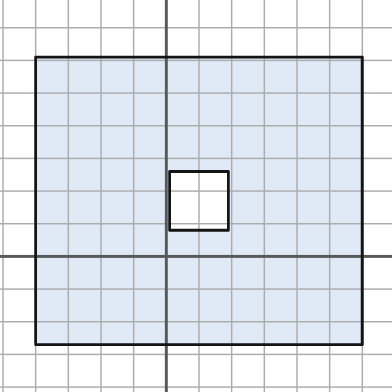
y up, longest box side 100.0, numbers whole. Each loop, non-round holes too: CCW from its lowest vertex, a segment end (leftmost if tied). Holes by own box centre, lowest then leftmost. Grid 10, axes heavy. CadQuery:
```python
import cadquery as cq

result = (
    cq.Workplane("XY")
    .moveTo(-40.0, -27.0)
    .lineTo(60.0, -27.0)
    .lineTo(60.0, 61.0)
    .lineTo(-40.0, 61.0)
    .close()
    .moveTo(1.0, 8.0)
    .lineTo(19.0, 8.0)
    .lineTo(19.0, 26.0)
    .lineTo(1.0, 26.0)
    .close()
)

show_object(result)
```